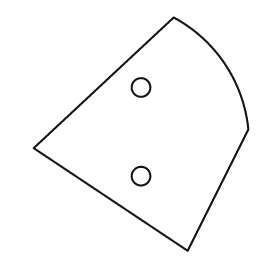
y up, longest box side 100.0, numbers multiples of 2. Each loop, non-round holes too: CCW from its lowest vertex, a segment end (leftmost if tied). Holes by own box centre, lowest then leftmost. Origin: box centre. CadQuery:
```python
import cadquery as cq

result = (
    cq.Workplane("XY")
    .moveTo(20.0, -50.0)
    .lineTo(46.0, 2.0)
    .threePointArc((36.0, 30.0), (14.0, 50.0))
    .lineTo(-46.0, -6.0)
    .close()
    .moveTo(0.0, -18.0)
    .circle(4.0)
    .moveTo(0.0, 20.0)
    .circle(4.0)
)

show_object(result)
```